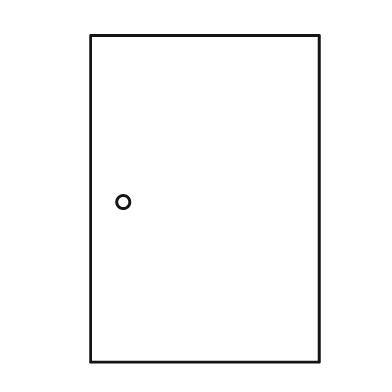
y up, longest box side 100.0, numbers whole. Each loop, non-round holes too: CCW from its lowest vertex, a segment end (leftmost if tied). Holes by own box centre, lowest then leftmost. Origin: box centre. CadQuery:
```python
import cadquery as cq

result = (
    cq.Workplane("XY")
    .moveTo(-35.0, -50.0)
    .lineTo(35.0, -50.0)
    .lineTo(35.0, 50.0)
    .lineTo(-35.0, 50.0)
    .close()
    .moveTo(-25.0, -1.0)
    .circle(2.0)
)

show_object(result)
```